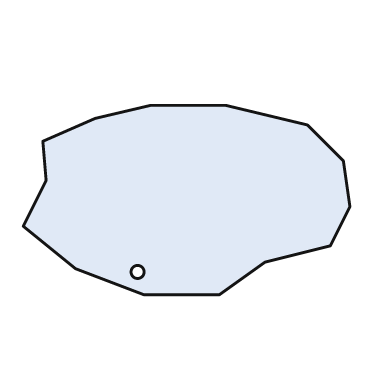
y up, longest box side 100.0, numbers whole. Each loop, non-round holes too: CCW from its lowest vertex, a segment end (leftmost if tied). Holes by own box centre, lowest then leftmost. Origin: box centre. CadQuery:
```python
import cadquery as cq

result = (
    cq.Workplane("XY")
    .moveTo(-13.0, -29.0)
    .lineTo(10.0, -29.0)
    .lineTo(24.0, -19.0)
    .lineTo(44.0, -14.0)
    .lineTo(50.0, -2.0)
    .lineTo(48.0, 12.0)
    .lineTo(37.0, 23.0)
    .lineTo(12.0, 29.0)
    .lineTo(-11.0, 29.0)
    .lineTo(-28.0, 25.0)
    .lineTo(-44.0, 18.0)
    .lineTo(-43.0, 6.0)
    .lineTo(-50.0, -8.0)
    .lineTo(-34.0, -21.0)
    .close()
    .moveTo(-15.0, -22.0)
    .circle(2.0)
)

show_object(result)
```